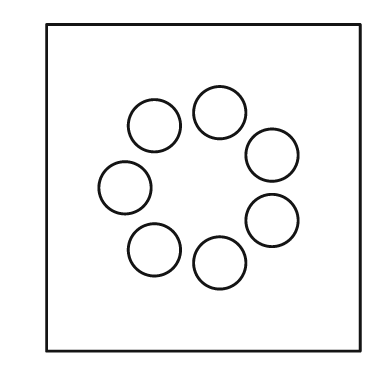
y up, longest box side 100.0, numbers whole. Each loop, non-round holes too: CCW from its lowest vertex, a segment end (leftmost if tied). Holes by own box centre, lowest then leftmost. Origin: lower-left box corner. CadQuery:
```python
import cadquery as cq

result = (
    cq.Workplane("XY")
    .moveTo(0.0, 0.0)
    .lineTo(96.0, 0.0)
    .lineTo(96.0, 100.0)
    .lineTo(0.0, 100.0)
    .close()
    .moveTo(53.0, 27.0)
    .circle(8.0)
    .moveTo(33.0, 31.0)
    .circle(8.0)
    .moveTo(69.0, 40.0)
    .circle(8.0)
    .moveTo(24.0, 50.0)
    .circle(8.0)
    .moveTo(69.0, 60.0)
    .circle(8.0)
    .moveTo(33.0, 69.0)
    .circle(8.0)
    .moveTo(53.0, 73.0)
    .circle(8.0)
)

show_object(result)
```